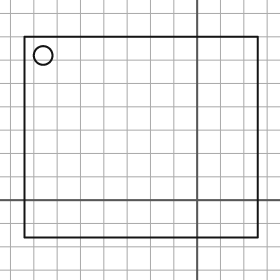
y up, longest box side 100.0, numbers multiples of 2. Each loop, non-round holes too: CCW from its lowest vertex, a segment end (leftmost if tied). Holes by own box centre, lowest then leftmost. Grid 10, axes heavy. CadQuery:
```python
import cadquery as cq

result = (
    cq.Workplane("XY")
    .moveTo(-74.0, -16.0)
    .lineTo(26.0, -16.0)
    .lineTo(26.0, 70.0)
    .lineTo(-74.0, 70.0)
    .close()
    .moveTo(-66.0, 62.0)
    .circle(4.0)
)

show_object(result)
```